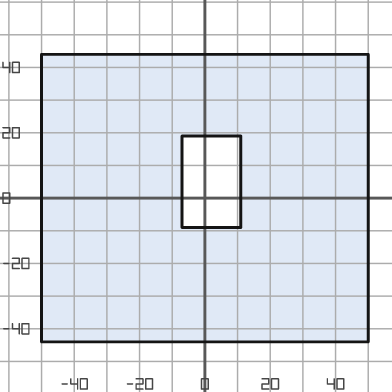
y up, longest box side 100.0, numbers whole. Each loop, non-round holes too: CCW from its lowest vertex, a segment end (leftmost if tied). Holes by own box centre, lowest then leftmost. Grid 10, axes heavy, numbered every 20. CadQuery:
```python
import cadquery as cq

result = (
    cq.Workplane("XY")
    .moveTo(-50.0, -44.0)
    .lineTo(50.0, -44.0)
    .lineTo(50.0, 44.0)
    .lineTo(-50.0, 44.0)
    .close()
    .moveTo(-7.0, -9.0)
    .lineTo(11.0, -9.0)
    .lineTo(11.0, 19.0)
    .lineTo(-7.0, 19.0)
    .close()
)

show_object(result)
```